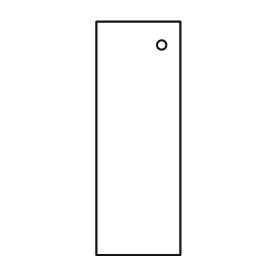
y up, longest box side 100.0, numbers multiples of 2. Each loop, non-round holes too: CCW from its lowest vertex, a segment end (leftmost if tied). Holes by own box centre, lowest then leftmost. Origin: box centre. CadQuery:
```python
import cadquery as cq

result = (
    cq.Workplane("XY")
    .moveTo(-18.0, -50.0)
    .lineTo(18.0, -50.0)
    .lineTo(18.0, 50.0)
    .lineTo(-18.0, 50.0)
    .close()
    .moveTo(10.0, 40.0)
    .circle(2.0)
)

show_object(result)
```